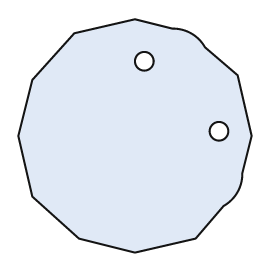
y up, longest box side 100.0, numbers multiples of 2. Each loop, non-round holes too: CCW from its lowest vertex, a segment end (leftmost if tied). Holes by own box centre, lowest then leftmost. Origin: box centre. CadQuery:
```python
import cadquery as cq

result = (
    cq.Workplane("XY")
    .moveTo(0.0, -50.0)
    .lineTo(26.0, -44.0)
    .lineTo(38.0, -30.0)
    .threePointArc((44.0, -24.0), (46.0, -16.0))
    .lineTo(50.0, 0.0)
    .lineTo(44.0, 26.0)
    .lineTo(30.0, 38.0)
    .threePointArc((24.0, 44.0), (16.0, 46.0))
    .lineTo(0.0, 50.0)
    .lineTo(-26.0, 44.0)
    .lineTo(-44.0, 24.0)
    .lineTo(-50.0, 0.0)
    .lineTo(-44.0, -26.0)
    .lineTo(-24.0, -44.0)
    .close()
    .moveTo(36.0, 2.0)
    .circle(4.0)
    .moveTo(4.0, 32.0)
    .circle(4.0)
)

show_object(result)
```